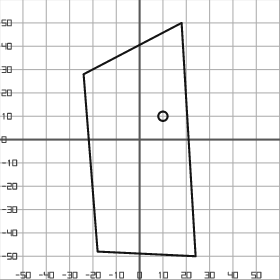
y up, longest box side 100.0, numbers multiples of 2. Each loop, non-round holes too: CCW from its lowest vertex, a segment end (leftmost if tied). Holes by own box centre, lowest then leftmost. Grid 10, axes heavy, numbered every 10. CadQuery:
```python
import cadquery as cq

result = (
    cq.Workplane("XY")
    .moveTo(24.0, -50.0)
    .lineTo(18.0, 50.0)
    .lineTo(-24.0, 28.0)
    .lineTo(-18.0, -48.0)
    .close()
    .moveTo(10.0, 10.0)
    .circle(2.0)
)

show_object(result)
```